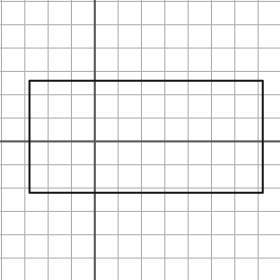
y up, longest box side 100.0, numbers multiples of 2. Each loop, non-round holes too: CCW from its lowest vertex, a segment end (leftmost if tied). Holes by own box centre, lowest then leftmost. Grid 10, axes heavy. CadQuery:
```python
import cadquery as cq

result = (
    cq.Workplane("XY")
    .moveTo(-28.0, -22.0)
    .lineTo(72.0, -22.0)
    .lineTo(72.0, 26.0)
    .lineTo(-28.0, 26.0)
    .close()
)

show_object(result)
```